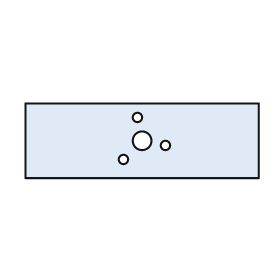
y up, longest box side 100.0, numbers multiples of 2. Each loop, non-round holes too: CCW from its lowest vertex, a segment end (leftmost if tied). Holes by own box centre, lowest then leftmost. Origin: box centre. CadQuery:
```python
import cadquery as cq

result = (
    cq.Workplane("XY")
    .moveTo(-50.0, -16.0)
    .lineTo(50.0, -16.0)
    .lineTo(50.0, 16.0)
    .lineTo(-50.0, 16.0)
    .close()
    .moveTo(-8.0, -8.0)
    .circle(2.0)
    .moveTo(10.0, -2.0)
    .circle(2.0)
    .moveTo(0.0, 0.0)
    .circle(4.0)
    .moveTo(-2.0, 10.0)
    .circle(2.0)
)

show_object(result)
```